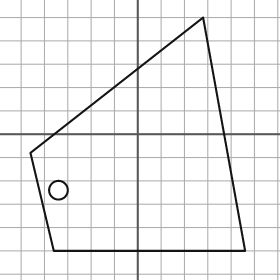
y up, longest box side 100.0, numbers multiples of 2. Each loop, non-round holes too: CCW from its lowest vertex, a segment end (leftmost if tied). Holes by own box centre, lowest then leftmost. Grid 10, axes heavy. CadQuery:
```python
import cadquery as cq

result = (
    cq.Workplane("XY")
    .moveTo(-36.0, -50.0)
    .lineTo(46.0, -50.0)
    .lineTo(28.0, 50.0)
    .lineTo(-46.0, -8.0)
    .close()
    .moveTo(-34.0, -24.0)
    .circle(4.0)
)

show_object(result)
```